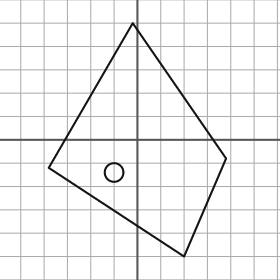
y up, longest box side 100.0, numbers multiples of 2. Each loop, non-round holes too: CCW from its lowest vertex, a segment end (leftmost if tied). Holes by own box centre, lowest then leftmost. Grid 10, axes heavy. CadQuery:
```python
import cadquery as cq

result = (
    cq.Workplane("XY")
    .moveTo(20.0, -50.0)
    .lineTo(38.0, -8.0)
    .lineTo(-2.0, 50.0)
    .lineTo(-38.0, -12.0)
    .close()
    .moveTo(-10.0, -14.0)
    .circle(4.0)
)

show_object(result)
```